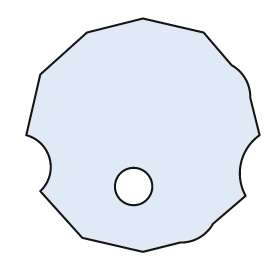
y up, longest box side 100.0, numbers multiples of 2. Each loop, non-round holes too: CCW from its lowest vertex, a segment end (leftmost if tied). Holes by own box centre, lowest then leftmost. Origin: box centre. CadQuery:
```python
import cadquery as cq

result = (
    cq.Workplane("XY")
    .moveTo(0.0, -50.0)
    .lineTo(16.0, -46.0)
    .threePointArc((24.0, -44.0), (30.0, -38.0))
    .lineTo(44.0, -26.0)
    .threePointArc((42.0, -12.0), (50.0, 0.0))
    .lineTo(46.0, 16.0)
    .threePointArc((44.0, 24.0), (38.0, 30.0))
    .lineTo(26.0, 44.0)
    .lineTo(0.0, 50.0)
    .lineTo(-24.0, 44.0)
    .lineTo(-44.0, 26.0)
    .lineTo(-50.0, 0.0)
    .threePointArc((-40.0, -10.0), (-44.0, -24.0))
    .lineTo(-26.0, -44.0)
    .close()
    .moveTo(-4.0, -22.0)
    .circle(8.0)
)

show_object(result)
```